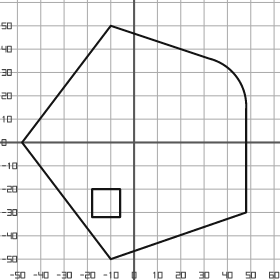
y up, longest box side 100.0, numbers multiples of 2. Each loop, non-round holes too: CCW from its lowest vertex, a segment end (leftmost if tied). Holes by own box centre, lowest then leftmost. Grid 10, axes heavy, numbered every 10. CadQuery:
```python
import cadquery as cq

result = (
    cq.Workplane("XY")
    .moveTo(-10.0, -50.0)
    .lineTo(48.0, -30.0)
    .lineTo(48.0, 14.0)
    .threePointArc((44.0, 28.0), (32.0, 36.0))
    .lineTo(-10.0, 50.0)
    .lineTo(-48.0, 0.0)
    .close()
    .moveTo(-18.0, -32.0)
    .lineTo(-6.0, -32.0)
    .lineTo(-6.0, -20.0)
    .lineTo(-18.0, -20.0)
    .close()
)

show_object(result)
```